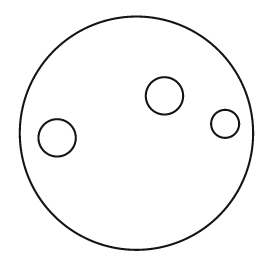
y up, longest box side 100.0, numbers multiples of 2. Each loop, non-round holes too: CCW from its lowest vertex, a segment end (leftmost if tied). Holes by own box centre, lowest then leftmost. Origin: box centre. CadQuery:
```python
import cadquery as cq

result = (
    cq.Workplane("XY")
    .moveTo(0.0, 0.0)
    .circle(50.0)
    .moveTo(-34.0, -2.0)
    .circle(8.0)
    .moveTo(38.0, 4.0)
    .circle(6.0)
    .moveTo(12.0, 16.0)
    .circle(8.0)
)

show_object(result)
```